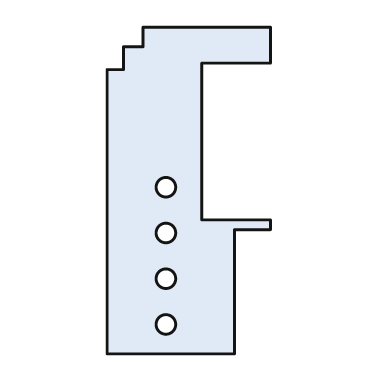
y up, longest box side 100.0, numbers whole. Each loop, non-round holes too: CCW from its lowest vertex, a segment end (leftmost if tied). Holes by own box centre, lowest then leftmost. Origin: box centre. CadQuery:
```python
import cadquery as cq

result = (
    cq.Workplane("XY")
    .moveTo(-25.0, -50.0)
    .lineTo(14.0, -50.0)
    .lineTo(14.0, -12.0)
    .lineTo(25.0, -12.0)
    .lineTo(25.0, -9.0)
    .lineTo(4.0, -9.0)
    .lineTo(4.0, 39.0)
    .lineTo(25.0, 39.0)
    .lineTo(25.0, 50.0)
    .lineTo(-14.0, 50.0)
    .lineTo(-14.0, 44.0)
    .lineTo(-20.0, 44.0)
    .lineTo(-20.0, 37.0)
    .lineTo(-25.0, 37.0)
    .close()
    .moveTo(-7.0, -41.0)
    .circle(3.0)
    .moveTo(-7.0, -27.0)
    .circle(3.0)
    .moveTo(-7.0, -13.0)
    .circle(3.0)
    .moveTo(-7.0, 1.0)
    .circle(3.0)
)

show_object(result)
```